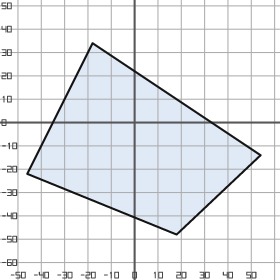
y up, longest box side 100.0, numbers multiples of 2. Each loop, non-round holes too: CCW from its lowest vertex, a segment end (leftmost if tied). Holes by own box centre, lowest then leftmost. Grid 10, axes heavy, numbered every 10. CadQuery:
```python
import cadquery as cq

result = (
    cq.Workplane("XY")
    .moveTo(18.0, -48.0)
    .lineTo(54.0, -14.0)
    .lineTo(-18.0, 34.0)
    .lineTo(-46.0, -22.0)
    .close()
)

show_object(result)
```